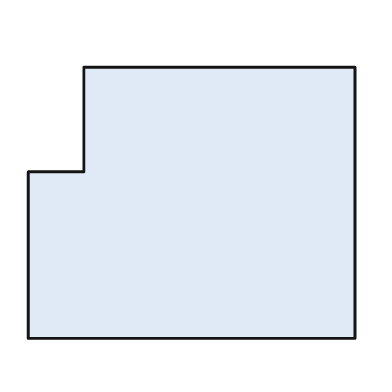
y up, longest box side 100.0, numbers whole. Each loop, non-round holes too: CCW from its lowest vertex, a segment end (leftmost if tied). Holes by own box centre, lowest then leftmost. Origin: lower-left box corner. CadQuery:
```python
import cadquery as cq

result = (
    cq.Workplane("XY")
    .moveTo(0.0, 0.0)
    .lineTo(100.0, 0.0)
    .lineTo(100.0, 83.0)
    .lineTo(17.0, 83.0)
    .lineTo(17.0, 51.0)
    .lineTo(0.0, 51.0)
    .close()
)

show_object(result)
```